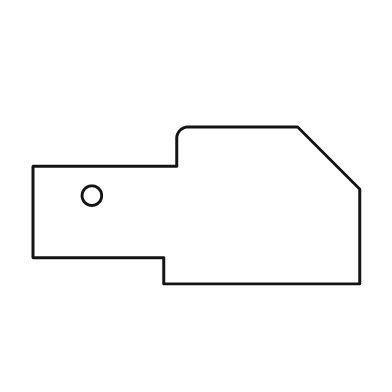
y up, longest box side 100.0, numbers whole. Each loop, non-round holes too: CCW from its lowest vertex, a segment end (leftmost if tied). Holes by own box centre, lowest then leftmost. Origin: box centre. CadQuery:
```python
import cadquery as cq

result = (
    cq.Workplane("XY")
    .moveTo(-10.0, -24.0)
    .lineTo(50.0, -24.0)
    .lineTo(50.0, 5.0)
    .lineTo(31.0, 24.0)
    .lineTo(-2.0, 24.0)
    .threePointArc((-5.0, 23.0), (-6.0, 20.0))
    .lineTo(-6.0, 12.0)
    .lineTo(-50.0, 12.0)
    .lineTo(-50.0, -16.0)
    .lineTo(-10.0, -16.0)
    .close()
    .moveTo(-32.0, 3.0)
    .circle(3.0)
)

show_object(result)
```